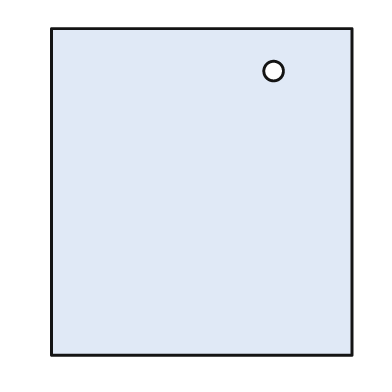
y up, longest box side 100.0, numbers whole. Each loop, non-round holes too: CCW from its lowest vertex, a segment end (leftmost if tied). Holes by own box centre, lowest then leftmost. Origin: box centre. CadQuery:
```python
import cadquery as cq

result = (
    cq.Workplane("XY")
    .moveTo(-46.0, -50.0)
    .lineTo(46.0, -50.0)
    .lineTo(46.0, 50.0)
    .lineTo(-46.0, 50.0)
    .close()
    .moveTo(22.0, 37.0)
    .circle(3.0)
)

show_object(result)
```